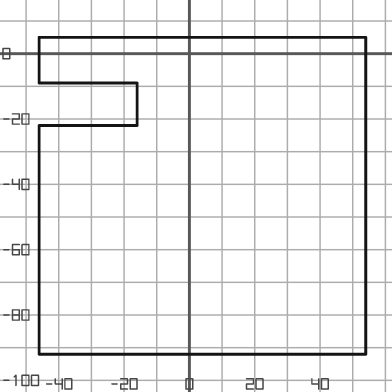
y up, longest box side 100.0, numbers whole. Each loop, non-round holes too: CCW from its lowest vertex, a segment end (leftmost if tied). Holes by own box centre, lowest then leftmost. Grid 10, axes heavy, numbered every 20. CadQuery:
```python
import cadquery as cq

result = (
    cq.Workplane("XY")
    .moveTo(-46.0, -92.0)
    .lineTo(54.0, -92.0)
    .lineTo(54.0, 5.0)
    .lineTo(-46.0, 5.0)
    .lineTo(-46.0, -9.0)
    .lineTo(-16.0, -9.0)
    .lineTo(-16.0, -22.0)
    .lineTo(-46.0, -22.0)
    .close()
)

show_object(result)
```